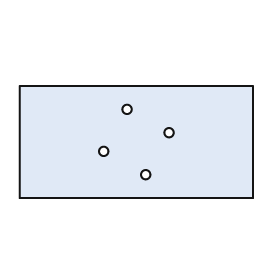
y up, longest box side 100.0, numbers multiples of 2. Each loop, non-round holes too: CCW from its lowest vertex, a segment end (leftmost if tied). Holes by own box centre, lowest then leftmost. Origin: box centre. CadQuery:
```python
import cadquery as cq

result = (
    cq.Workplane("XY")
    .moveTo(-50.0, -24.0)
    .lineTo(50.0, -24.0)
    .lineTo(50.0, 24.0)
    .lineTo(-50.0, 24.0)
    .close()
    .moveTo(4.0, -14.0)
    .circle(2.0)
    .moveTo(-14.0, -4.0)
    .circle(2.0)
    .moveTo(14.0, 4.0)
    .circle(2.0)
    .moveTo(-4.0, 14.0)
    .circle(2.0)
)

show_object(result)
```